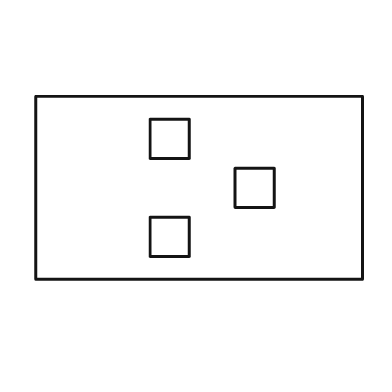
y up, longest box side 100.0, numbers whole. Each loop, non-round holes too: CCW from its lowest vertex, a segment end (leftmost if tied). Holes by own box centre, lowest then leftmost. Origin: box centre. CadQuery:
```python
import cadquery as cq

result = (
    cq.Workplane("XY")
    .moveTo(-50.0, -28.0)
    .lineTo(50.0, -28.0)
    .lineTo(50.0, 28.0)
    .lineTo(-50.0, 28.0)
    .close()
    .moveTo(-15.0, -21.0)
    .lineTo(-3.0, -21.0)
    .lineTo(-3.0, -9.0)
    .lineTo(-15.0, -9.0)
    .close()
    .moveTo(11.0, -6.0)
    .lineTo(23.0, -6.0)
    .lineTo(23.0, 6.0)
    .lineTo(11.0, 6.0)
    .close()
    .moveTo(-15.0, 9.0)
    .lineTo(-3.0, 9.0)
    .lineTo(-3.0, 21.0)
    .lineTo(-15.0, 21.0)
    .close()
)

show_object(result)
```